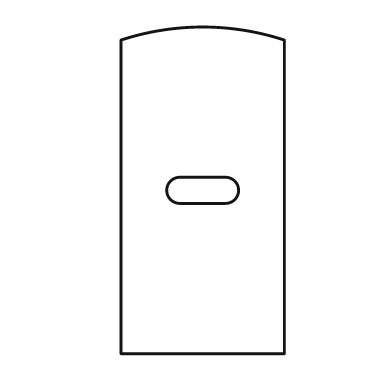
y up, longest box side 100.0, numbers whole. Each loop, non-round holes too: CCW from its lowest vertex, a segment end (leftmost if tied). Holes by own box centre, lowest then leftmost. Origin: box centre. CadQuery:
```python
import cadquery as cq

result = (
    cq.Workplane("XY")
    .moveTo(-25.0, -50.0)
    .lineTo(25.0, -50.0)
    .lineTo(25.0, 46.0)
    .threePointArc((0.0, 50.0), (-25.0, 46.0))
    .close()
    .moveTo(-7.0, -4.0)
    .lineTo(7.0, -4.0)
    .threePointArc((11.0, 0.0), (7.0, 4.0))
    .lineTo(-7.0, 4.0)
    .threePointArc((-11.0, 0.0), (-7.0, -4.0))
    .close()
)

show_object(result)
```